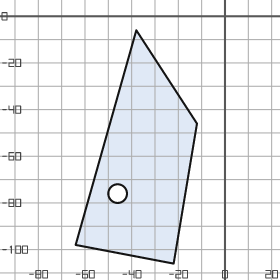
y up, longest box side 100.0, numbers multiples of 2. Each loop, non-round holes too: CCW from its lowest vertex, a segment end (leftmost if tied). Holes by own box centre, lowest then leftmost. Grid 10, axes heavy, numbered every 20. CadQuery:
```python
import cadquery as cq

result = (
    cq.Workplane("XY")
    .moveTo(-22.0, -106.0)
    .lineTo(-12.0, -46.0)
    .lineTo(-38.0, -6.0)
    .lineTo(-64.0, -98.0)
    .close()
    .moveTo(-46.0, -76.0)
    .circle(4.0)
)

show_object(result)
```